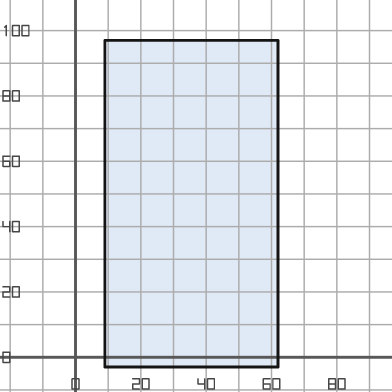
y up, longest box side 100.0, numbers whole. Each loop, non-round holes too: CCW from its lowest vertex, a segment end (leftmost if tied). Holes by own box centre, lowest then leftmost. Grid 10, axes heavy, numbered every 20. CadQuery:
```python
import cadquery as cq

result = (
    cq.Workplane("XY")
    .moveTo(9.0, -3.0)
    .lineTo(62.0, -3.0)
    .lineTo(62.0, 97.0)
    .lineTo(9.0, 97.0)
    .close()
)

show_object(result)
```